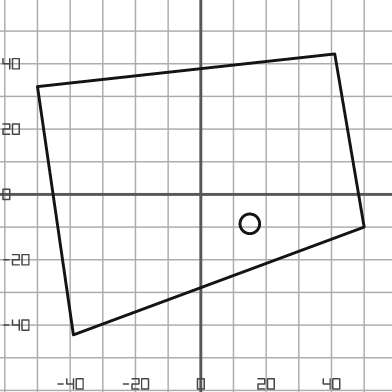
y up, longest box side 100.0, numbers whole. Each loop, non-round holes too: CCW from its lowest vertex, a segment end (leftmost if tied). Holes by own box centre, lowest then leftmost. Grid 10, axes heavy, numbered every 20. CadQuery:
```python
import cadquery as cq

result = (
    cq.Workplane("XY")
    .moveTo(-39.0, -43.0)
    .lineTo(50.0, -10.0)
    .lineTo(41.0, 43.0)
    .lineTo(-50.0, 33.0)
    .close()
    .moveTo(15.0, -9.0)
    .circle(3.0)
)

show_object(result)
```